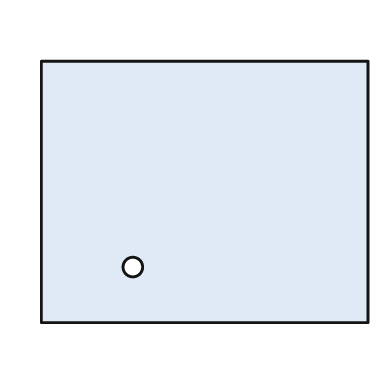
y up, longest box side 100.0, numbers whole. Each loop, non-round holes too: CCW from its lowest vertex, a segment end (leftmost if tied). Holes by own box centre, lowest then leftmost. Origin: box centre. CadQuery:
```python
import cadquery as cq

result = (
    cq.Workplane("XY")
    .moveTo(-50.0, -40.0)
    .lineTo(50.0, -40.0)
    .lineTo(50.0, 40.0)
    .lineTo(-50.0, 40.0)
    .close()
    .moveTo(-22.0, -23.0)
    .circle(3.0)
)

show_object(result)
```